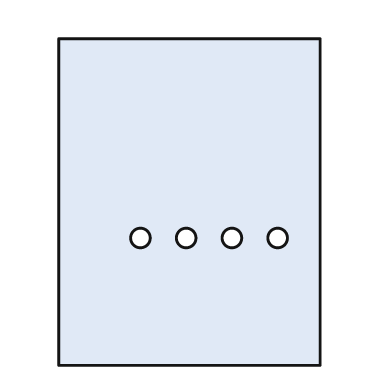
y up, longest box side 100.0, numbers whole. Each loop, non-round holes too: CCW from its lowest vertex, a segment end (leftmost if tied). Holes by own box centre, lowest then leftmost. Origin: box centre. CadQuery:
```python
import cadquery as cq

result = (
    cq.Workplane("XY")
    .moveTo(-40.0, -50.0)
    .lineTo(40.0, -50.0)
    .lineTo(40.0, 50.0)
    .lineTo(-40.0, 50.0)
    .close()
    .moveTo(-15.0, -11.0)
    .circle(3.0)
    .moveTo(-1.0, -11.0)
    .circle(3.0)
    .moveTo(13.0, -11.0)
    .circle(3.0)
    .moveTo(27.0, -11.0)
    .circle(3.0)
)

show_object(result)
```